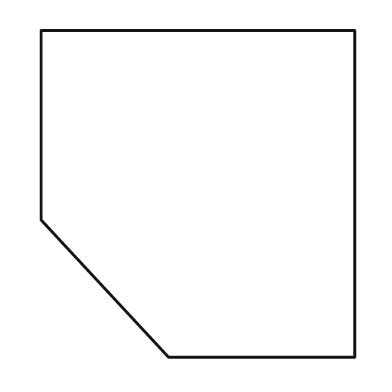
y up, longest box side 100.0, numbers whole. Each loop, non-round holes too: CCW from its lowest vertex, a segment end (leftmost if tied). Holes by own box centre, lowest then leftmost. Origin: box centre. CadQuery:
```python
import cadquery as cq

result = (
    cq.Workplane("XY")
    .moveTo(-9.0, -50.0)
    .lineTo(48.0, -50.0)
    .lineTo(48.0, 50.0)
    .lineTo(-48.0, 50.0)
    .lineTo(-48.0, -8.0)
    .close()
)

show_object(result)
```